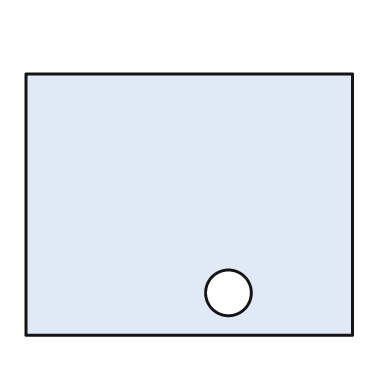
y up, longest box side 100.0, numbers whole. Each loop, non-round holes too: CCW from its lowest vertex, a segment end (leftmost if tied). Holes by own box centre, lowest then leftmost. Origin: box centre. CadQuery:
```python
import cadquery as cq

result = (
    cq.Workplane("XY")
    .moveTo(-50.0, -40.0)
    .lineTo(50.0, -40.0)
    .lineTo(50.0, 40.0)
    .lineTo(-50.0, 40.0)
    .close()
    .moveTo(12.0, -27.0)
    .circle(7.0)
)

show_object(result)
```